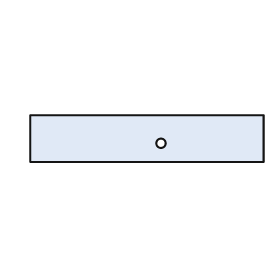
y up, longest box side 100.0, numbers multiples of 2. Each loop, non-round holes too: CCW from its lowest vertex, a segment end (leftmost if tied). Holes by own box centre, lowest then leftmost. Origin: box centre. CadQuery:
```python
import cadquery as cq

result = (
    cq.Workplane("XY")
    .moveTo(-50.0, -10.0)
    .lineTo(50.0, -10.0)
    .lineTo(50.0, 10.0)
    .lineTo(-50.0, 10.0)
    .close()
    .moveTo(6.0, -2.0)
    .circle(2.0)
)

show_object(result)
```